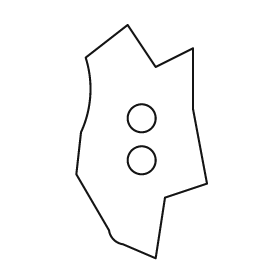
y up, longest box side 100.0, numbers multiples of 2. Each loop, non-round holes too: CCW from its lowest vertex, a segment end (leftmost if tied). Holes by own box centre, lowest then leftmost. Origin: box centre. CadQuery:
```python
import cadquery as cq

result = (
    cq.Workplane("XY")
    .moveTo(6.0, -50.0)
    .lineTo(10.0, -24.0)
    .lineTo(28.0, -18.0)
    .lineTo(22.0, 14.0)
    .lineTo(22.0, 40.0)
    .lineTo(6.0, 32.0)
    .lineTo(-6.0, 50.0)
    .lineTo(-24.0, 36.0)
    .threePointArc((-22.0, 20.0), (-26.0, 4.0))
    .lineTo(-28.0, -14.0)
    .lineTo(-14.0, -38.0)
    .threePointArc((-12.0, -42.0), (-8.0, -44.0))
    .close()
    .moveTo(0.0, -8.0)
    .circle(6.0)
    .moveTo(0.0, 10.0)
    .circle(6.0)
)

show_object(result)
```